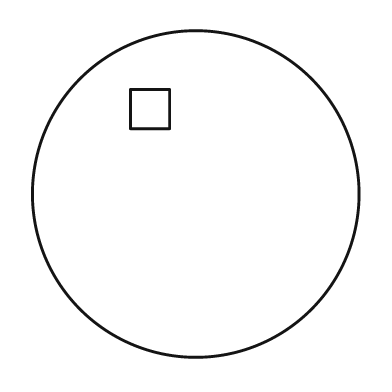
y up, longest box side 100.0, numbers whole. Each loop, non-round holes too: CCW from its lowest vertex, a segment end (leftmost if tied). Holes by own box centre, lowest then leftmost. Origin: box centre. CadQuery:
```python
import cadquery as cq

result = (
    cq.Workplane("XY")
    .moveTo(0.0, 0.0)
    .circle(50.0)
    .moveTo(-20.0, 20.0)
    .lineTo(-8.0, 20.0)
    .lineTo(-8.0, 32.0)
    .lineTo(-20.0, 32.0)
    .close()
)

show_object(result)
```